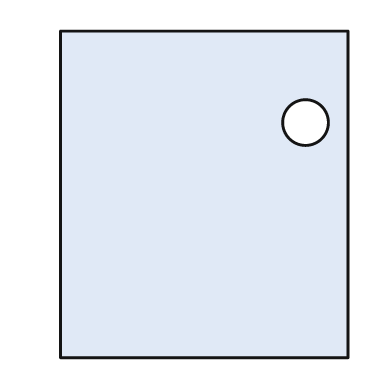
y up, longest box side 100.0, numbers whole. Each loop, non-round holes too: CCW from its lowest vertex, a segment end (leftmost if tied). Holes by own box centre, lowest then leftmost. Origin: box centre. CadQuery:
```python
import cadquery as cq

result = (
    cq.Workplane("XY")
    .moveTo(-44.0, -50.0)
    .lineTo(44.0, -50.0)
    .lineTo(44.0, 50.0)
    .lineTo(-44.0, 50.0)
    .close()
    .moveTo(31.0, 22.0)
    .circle(7.0)
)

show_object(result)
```